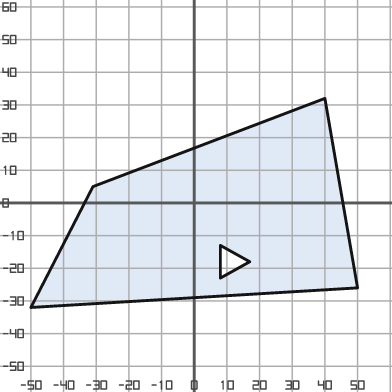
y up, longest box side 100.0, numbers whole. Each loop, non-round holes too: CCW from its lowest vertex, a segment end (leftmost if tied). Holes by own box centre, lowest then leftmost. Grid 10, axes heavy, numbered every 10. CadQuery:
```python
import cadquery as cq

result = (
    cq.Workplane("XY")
    .moveTo(-50.0, -32.0)
    .lineTo(50.0, -26.0)
    .lineTo(40.0, 32.0)
    .lineTo(-31.0, 5.0)
    .close()
    .moveTo(8.0, -23.0)
    .lineTo(17.0, -18.0)
    .lineTo(8.0, -13.0)
    .close()
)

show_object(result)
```